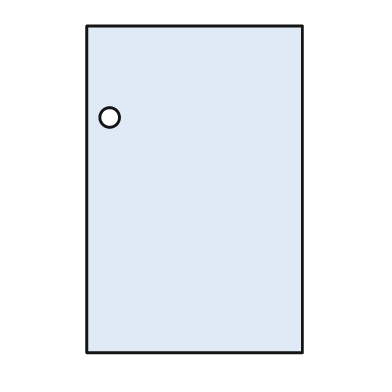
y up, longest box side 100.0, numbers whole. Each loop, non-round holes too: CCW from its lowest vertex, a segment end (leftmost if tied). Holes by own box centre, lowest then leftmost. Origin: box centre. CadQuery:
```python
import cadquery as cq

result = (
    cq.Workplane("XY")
    .moveTo(-33.0, -50.0)
    .lineTo(33.0, -50.0)
    .lineTo(33.0, 50.0)
    .lineTo(-33.0, 50.0)
    .close()
    .moveTo(-26.0, 22.0)
    .circle(3.0)
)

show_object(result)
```